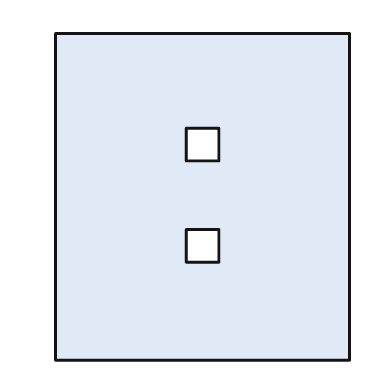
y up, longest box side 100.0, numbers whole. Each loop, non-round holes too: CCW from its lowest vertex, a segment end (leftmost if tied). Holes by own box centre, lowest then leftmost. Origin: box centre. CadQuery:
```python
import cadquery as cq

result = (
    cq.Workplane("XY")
    .moveTo(-45.0, -50.0)
    .lineTo(45.0, -50.0)
    .lineTo(45.0, 50.0)
    .lineTo(-45.0, 50.0)
    .close()
    .moveTo(-5.0, -20.0)
    .lineTo(5.0, -20.0)
    .lineTo(5.0, -10.0)
    .lineTo(-5.0, -10.0)
    .close()
    .moveTo(-5.0, 11.0)
    .lineTo(5.0, 11.0)
    .lineTo(5.0, 21.0)
    .lineTo(-5.0, 21.0)
    .close()
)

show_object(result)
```